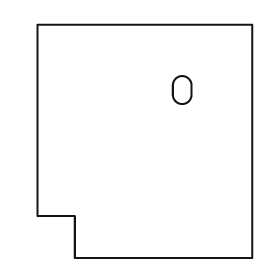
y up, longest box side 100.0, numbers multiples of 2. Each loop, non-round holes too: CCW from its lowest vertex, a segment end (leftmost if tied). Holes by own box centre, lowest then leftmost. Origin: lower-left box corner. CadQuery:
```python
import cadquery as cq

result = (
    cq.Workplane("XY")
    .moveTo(16.0, 0.0)
    .lineTo(92.0, 0.0)
    .lineTo(92.0, 100.0)
    .lineTo(0.0, 100.0)
    .lineTo(0.0, 18.0)
    .lineTo(16.0, 18.0)
    .close()
    .moveTo(58.0, 70.0)
    .threePointArc((62.0, 66.0), (66.0, 70.0))
    .lineTo(66.0, 74.0)
    .threePointArc((62.0, 78.0), (58.0, 74.0))
    .close()
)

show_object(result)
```